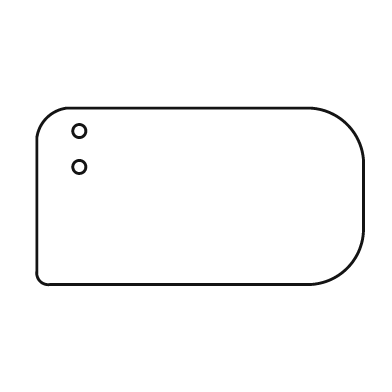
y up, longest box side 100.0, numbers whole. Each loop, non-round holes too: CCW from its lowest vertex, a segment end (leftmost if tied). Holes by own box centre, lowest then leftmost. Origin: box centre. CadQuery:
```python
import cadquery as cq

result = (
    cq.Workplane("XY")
    .moveTo(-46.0, -27.0)
    .lineTo(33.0, -27.0)
    .threePointArc((45.0, -22.0), (50.0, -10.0))
    .lineTo(50.0, 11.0)
    .threePointArc((45.0, 22.0), (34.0, 27.0))
    .lineTo(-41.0, 27.0)
    .threePointArc((-47.0, 24.0), (-50.0, 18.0))
    .lineTo(-50.0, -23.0)
    .threePointArc((-49.0, -26.0), (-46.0, -27.0))
    .close()
    .moveTo(-37.0, 9.0)
    .circle(2.0)
    .moveTo(-37.0, 20.0)
    .circle(2.0)
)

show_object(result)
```